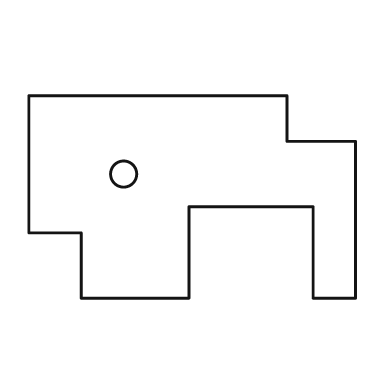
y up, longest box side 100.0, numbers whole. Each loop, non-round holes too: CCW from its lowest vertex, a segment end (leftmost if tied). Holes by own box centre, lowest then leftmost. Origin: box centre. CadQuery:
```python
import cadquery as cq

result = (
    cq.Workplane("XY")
    .moveTo(-34.0, -31.0)
    .lineTo(-1.0, -31.0)
    .lineTo(-1.0, -3.0)
    .lineTo(37.0, -3.0)
    .lineTo(37.0, -31.0)
    .lineTo(50.0, -31.0)
    .lineTo(50.0, 17.0)
    .lineTo(29.0, 17.0)
    .lineTo(29.0, 31.0)
    .lineTo(-50.0, 31.0)
    .lineTo(-50.0, -11.0)
    .lineTo(-34.0, -11.0)
    .close()
    .moveTo(-21.0, 7.0)
    .circle(4.0)
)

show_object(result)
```